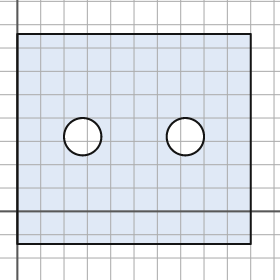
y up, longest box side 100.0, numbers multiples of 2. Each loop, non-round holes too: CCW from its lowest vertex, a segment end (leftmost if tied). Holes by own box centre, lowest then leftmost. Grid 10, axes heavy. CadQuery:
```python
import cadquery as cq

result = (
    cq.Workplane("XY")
    .moveTo(0.0, -14.0)
    .lineTo(100.0, -14.0)
    .lineTo(100.0, 76.0)
    .lineTo(0.0, 76.0)
    .close()
    .moveTo(28.0, 32.0)
    .circle(8.0)
    .moveTo(72.0, 32.0)
    .circle(8.0)
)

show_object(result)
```